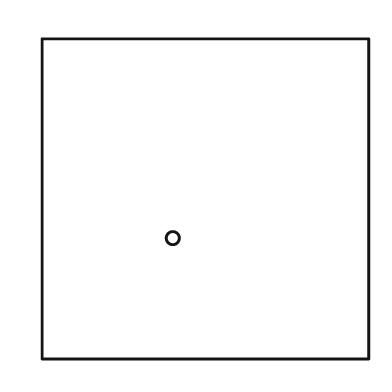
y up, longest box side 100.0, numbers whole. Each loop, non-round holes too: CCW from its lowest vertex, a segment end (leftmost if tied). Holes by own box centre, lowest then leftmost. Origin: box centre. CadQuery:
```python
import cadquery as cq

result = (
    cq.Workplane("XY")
    .moveTo(-50.0, -49.0)
    .lineTo(50.0, -49.0)
    .lineTo(50.0, 49.0)
    .lineTo(-50.0, 49.0)
    .close()
    .moveTo(-10.0, -12.0)
    .circle(2.0)
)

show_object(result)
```